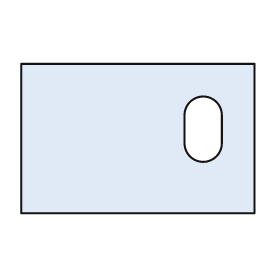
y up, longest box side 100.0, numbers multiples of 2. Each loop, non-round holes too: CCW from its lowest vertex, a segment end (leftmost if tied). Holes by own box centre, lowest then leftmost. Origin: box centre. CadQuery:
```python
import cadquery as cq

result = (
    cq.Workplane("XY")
    .moveTo(-50.0, -32.0)
    .lineTo(50.0, -32.0)
    .lineTo(50.0, 32.0)
    .lineTo(-50.0, 32.0)
    .close()
    .moveTo(20.0, -2.0)
    .threePointArc((28.0, -10.0), (36.0, -2.0))
    .lineTo(36.0, 10.0)
    .threePointArc((28.0, 18.0), (20.0, 10.0))
    .close()
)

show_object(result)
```